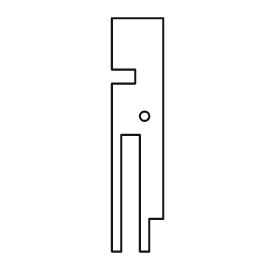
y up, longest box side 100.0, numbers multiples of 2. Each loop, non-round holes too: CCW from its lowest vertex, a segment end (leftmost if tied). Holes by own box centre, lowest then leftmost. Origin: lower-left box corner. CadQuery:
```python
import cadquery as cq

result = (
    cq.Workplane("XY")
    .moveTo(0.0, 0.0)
    .lineTo(4.0, 0.0)
    .lineTo(4.0, 50.0)
    .lineTo(12.0, 50.0)
    .lineTo(12.0, 0.0)
    .lineTo(16.0, 0.0)
    .lineTo(16.0, 14.0)
    .lineTo(22.0, 14.0)
    .lineTo(22.0, 100.0)
    .lineTo(0.0, 100.0)
    .lineTo(0.0, 78.0)
    .lineTo(10.0, 78.0)
    .lineTo(10.0, 72.0)
    .lineTo(0.0, 72.0)
    .close()
    .moveTo(14.0, 58.0)
    .circle(2.0)
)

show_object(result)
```